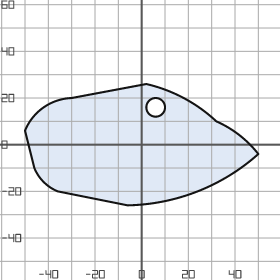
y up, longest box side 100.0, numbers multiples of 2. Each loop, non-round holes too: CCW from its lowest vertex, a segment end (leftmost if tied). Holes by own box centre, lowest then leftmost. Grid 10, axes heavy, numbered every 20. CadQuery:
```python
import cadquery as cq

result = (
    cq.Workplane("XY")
    .moveTo(-6.0, -26.0)
    .threePointArc((24.0, -20.0), (50.0, -4.0))
    .threePointArc((42.0, 4.0), (32.0, 10.0))
    .threePointArc((18.0, 20.0), (2.0, 26.0))
    .lineTo(-30.0, 20.0)
    .threePointArc((-42.0, 16.0), (-50.0, 6.0))
    .lineTo(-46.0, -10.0)
    .threePointArc((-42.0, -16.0), (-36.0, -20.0))
    .close()
    .moveTo(6.0, 16.0)
    .circle(4.0)
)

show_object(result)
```